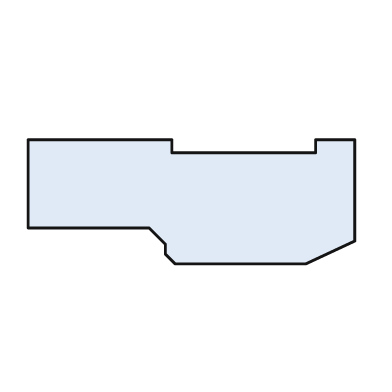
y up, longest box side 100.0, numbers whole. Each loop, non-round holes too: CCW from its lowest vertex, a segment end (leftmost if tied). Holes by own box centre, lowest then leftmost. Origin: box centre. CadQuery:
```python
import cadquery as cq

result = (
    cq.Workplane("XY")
    .moveTo(-5.0, -19.0)
    .lineTo(35.0, -19.0)
    .lineTo(50.0, -12.0)
    .lineTo(50.0, 19.0)
    .lineTo(38.0, 19.0)
    .lineTo(38.0, 15.0)
    .lineTo(-6.0, 15.0)
    .lineTo(-6.0, 19.0)
    .lineTo(-50.0, 19.0)
    .lineTo(-50.0, -8.0)
    .lineTo(-13.0, -8.0)
    .lineTo(-8.0, -13.0)
    .lineTo(-8.0, -16.0)
    .close()
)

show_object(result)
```